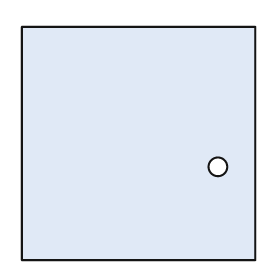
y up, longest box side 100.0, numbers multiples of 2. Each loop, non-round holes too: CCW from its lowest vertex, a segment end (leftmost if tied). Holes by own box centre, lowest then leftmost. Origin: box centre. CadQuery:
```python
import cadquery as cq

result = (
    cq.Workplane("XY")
    .moveTo(-50.0, -50.0)
    .lineTo(50.0, -50.0)
    .lineTo(50.0, 50.0)
    .lineTo(-50.0, 50.0)
    .close()
    .moveTo(34.0, -10.0)
    .circle(4.0)
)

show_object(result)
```